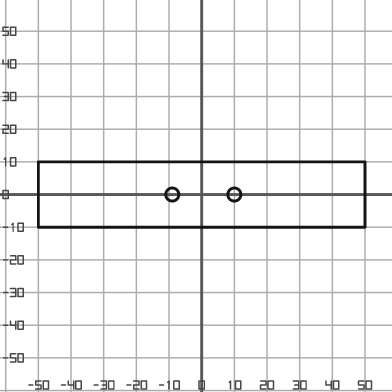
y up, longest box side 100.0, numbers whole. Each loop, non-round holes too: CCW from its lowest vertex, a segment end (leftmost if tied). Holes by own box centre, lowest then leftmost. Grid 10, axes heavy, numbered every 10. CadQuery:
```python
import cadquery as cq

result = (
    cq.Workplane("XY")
    .moveTo(-50.0, -10.0)
    .lineTo(50.0, -10.0)
    .lineTo(50.0, 10.0)
    .lineTo(-50.0, 10.0)
    .close()
    .moveTo(-9.0, 0.0)
    .circle(2.0)
    .moveTo(10.0, 0.0)
    .circle(2.0)
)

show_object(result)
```